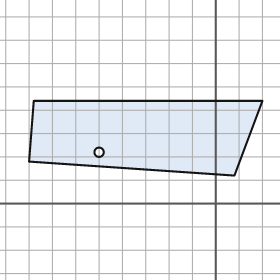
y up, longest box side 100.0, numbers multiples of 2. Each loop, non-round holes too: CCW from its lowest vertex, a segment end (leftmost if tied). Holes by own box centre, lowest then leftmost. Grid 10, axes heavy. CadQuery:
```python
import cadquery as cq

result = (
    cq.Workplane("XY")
    .moveTo(8.0, 12.0)
    .lineTo(20.0, 44.0)
    .lineTo(-78.0, 44.0)
    .lineTo(-80.0, 18.0)
    .close()
    .moveTo(-50.0, 22.0)
    .circle(2.0)
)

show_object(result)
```